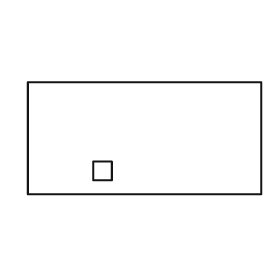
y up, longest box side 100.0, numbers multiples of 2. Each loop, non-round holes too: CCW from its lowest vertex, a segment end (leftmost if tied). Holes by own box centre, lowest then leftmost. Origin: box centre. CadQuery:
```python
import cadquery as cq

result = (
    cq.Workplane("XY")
    .moveTo(-50.0, -24.0)
    .lineTo(50.0, -24.0)
    .lineTo(50.0, 24.0)
    .lineTo(-50.0, 24.0)
    .close()
    .moveTo(-22.0, -18.0)
    .lineTo(-14.0, -18.0)
    .lineTo(-14.0, -10.0)
    .lineTo(-22.0, -10.0)
    .close()
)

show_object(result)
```